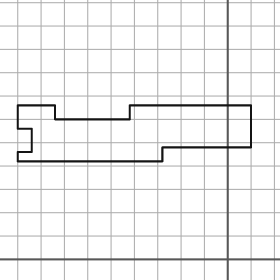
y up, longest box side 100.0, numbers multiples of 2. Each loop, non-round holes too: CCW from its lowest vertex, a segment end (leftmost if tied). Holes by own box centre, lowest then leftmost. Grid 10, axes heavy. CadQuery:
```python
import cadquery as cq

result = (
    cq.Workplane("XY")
    .moveTo(-90.0, 42.0)
    .lineTo(-28.0, 42.0)
    .lineTo(-28.0, 48.0)
    .lineTo(10.0, 48.0)
    .lineTo(10.0, 66.0)
    .lineTo(-42.0, 66.0)
    .lineTo(-42.0, 60.0)
    .lineTo(-74.0, 60.0)
    .lineTo(-74.0, 66.0)
    .lineTo(-90.0, 66.0)
    .lineTo(-90.0, 56.0)
    .lineTo(-84.0, 56.0)
    .lineTo(-84.0, 46.0)
    .lineTo(-90.0, 46.0)
    .close()
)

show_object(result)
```